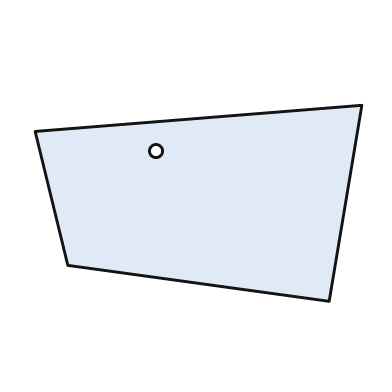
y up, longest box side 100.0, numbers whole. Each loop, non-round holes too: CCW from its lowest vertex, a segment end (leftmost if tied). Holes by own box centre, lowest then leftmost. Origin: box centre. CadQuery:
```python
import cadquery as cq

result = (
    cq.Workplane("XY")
    .moveTo(40.0, -30.0)
    .lineTo(50.0, 30.0)
    .lineTo(-50.0, 22.0)
    .lineTo(-40.0, -19.0)
    .close()
    .moveTo(-13.0, 16.0)
    .circle(2.0)
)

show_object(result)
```